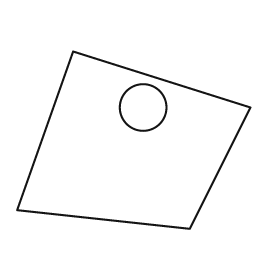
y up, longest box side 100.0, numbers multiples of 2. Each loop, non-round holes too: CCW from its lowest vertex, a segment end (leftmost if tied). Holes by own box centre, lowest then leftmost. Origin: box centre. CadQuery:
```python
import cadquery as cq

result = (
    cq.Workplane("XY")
    .moveTo(24.0, -38.0)
    .lineTo(50.0, 14.0)
    .lineTo(-26.0, 38.0)
    .lineTo(-50.0, -30.0)
    .close()
    .moveTo(4.0, 14.0)
    .circle(10.0)
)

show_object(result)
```